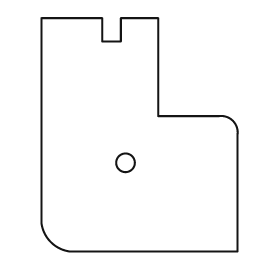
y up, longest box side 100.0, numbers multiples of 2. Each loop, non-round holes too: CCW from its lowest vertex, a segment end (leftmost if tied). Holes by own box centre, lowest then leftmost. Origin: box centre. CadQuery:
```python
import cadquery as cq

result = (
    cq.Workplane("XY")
    .moveTo(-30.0, -50.0)
    .lineTo(42.0, -50.0)
    .lineTo(42.0, 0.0)
    .threePointArc((40.0, 6.0), (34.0, 8.0))
    .lineTo(8.0, 8.0)
    .lineTo(8.0, 50.0)
    .lineTo(-8.0, 50.0)
    .lineTo(-8.0, 40.0)
    .lineTo(-16.0, 40.0)
    .lineTo(-16.0, 50.0)
    .lineTo(-42.0, 50.0)
    .lineTo(-42.0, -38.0)
    .threePointArc((-38.0, -46.0), (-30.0, -50.0))
    .close()
    .moveTo(-6.0, -12.0)
    .circle(4.0)
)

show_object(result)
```